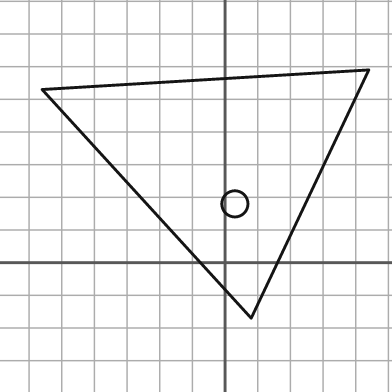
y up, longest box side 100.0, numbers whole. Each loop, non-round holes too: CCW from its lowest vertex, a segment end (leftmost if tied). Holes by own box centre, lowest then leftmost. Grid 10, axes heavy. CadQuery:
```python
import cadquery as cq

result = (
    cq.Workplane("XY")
    .moveTo(8.0, -17.0)
    .lineTo(44.0, 59.0)
    .lineTo(-56.0, 53.0)
    .close()
    .moveTo(3.0, 18.0)
    .circle(4.0)
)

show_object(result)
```